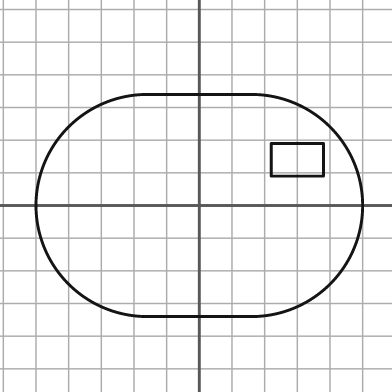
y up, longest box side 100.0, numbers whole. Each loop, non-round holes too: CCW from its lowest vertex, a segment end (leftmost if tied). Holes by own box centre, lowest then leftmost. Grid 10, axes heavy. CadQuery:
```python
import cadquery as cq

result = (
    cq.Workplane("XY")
    .moveTo(-16.0, -34.0)
    .lineTo(16.0, -34.0)
    .threePointArc((50.0, 0.0), (16.0, 34.0))
    .lineTo(-16.0, 34.0)
    .threePointArc((-50.0, 0.0), (-16.0, -34.0))
    .close()
    .moveTo(22.0, 9.0)
    .lineTo(38.0, 9.0)
    .lineTo(38.0, 19.0)
    .lineTo(22.0, 19.0)
    .close()
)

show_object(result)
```